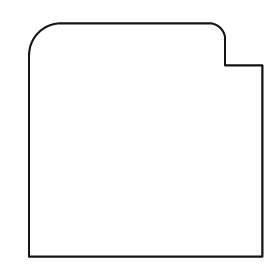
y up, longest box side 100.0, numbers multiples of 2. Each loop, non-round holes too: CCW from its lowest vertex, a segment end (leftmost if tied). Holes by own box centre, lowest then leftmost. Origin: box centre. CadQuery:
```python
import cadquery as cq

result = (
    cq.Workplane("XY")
    .moveTo(-50.0, -50.0)
    .lineTo(50.0, -50.0)
    .lineTo(50.0, 32.0)
    .lineTo(34.0, 32.0)
    .lineTo(34.0, 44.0)
    .threePointArc((32.0, 48.0), (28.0, 50.0))
    .lineTo(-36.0, 50.0)
    .threePointArc((-46.0, 46.0), (-50.0, 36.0))
    .close()
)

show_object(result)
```